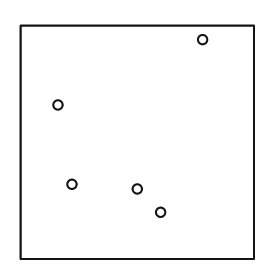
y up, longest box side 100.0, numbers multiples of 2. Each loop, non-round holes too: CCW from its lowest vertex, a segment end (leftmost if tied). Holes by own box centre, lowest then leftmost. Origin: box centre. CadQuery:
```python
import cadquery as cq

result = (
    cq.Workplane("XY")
    .moveTo(-50.0, -50.0)
    .lineTo(50.0, -50.0)
    .lineTo(50.0, 50.0)
    .lineTo(-50.0, 50.0)
    .close()
    .moveTo(10.0, -30.0)
    .circle(2.0)
    .moveTo(0.0, -20.0)
    .circle(2.0)
    .moveTo(-28.0, -18.0)
    .circle(2.0)
    .moveTo(-34.0, 16.0)
    .circle(2.0)
    .moveTo(28.0, 44.0)
    .circle(2.0)
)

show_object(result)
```